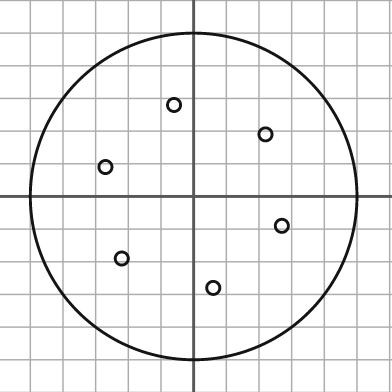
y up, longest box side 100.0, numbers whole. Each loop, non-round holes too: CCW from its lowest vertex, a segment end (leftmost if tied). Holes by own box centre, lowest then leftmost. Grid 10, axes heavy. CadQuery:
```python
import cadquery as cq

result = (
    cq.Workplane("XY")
    .moveTo(0.0, 0.0)
    .circle(50.0)
    .moveTo(6.0, -28.0)
    .circle(2.0)
    .moveTo(-22.0, -19.0)
    .circle(2.0)
    .moveTo(27.0, -9.0)
    .circle(2.0)
    .moveTo(-27.0, 9.0)
    .circle(2.0)
    .moveTo(22.0, 19.0)
    .circle(2.0)
    .moveTo(-6.0, 28.0)
    .circle(2.0)
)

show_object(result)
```